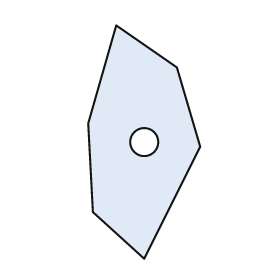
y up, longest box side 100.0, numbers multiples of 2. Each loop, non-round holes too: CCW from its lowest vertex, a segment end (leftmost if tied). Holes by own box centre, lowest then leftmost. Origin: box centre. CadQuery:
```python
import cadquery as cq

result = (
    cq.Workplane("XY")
    .moveTo(0.0, -50.0)
    .lineTo(24.0, -2.0)
    .lineTo(14.0, 32.0)
    .lineTo(-12.0, 50.0)
    .lineTo(-24.0, 8.0)
    .lineTo(-22.0, -30.0)
    .close()
    .moveTo(0.0, 0.0)
    .circle(6.0)
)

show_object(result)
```